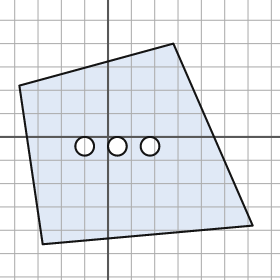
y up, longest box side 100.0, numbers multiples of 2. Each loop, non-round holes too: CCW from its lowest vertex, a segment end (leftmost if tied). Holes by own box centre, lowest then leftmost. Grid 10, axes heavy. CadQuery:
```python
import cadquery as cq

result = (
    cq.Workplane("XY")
    .moveTo(-28.0, -46.0)
    .lineTo(62.0, -38.0)
    .lineTo(28.0, 40.0)
    .lineTo(-38.0, 22.0)
    .close()
    .moveTo(-10.0, -4.0)
    .circle(4.0)
    .moveTo(4.0, -4.0)
    .circle(4.0)
    .moveTo(18.0, -4.0)
    .circle(4.0)
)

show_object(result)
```